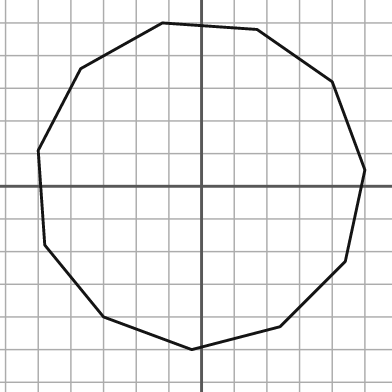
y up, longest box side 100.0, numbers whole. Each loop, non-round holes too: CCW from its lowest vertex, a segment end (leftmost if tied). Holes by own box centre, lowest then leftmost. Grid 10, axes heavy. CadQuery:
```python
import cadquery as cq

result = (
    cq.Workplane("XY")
    .moveTo(-3.0, -50.0)
    .lineTo(24.0, -43.0)
    .lineTo(44.0, -23.0)
    .lineTo(50.0, 5.0)
    .lineTo(40.0, 32.0)
    .lineTo(17.0, 48.0)
    .lineTo(-12.0, 50.0)
    .lineTo(-37.0, 36.0)
    .lineTo(-50.0, 11.0)
    .lineTo(-48.0, -18.0)
    .lineTo(-30.0, -40.0)
    .close()
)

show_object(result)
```